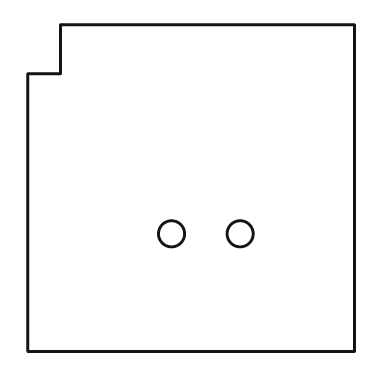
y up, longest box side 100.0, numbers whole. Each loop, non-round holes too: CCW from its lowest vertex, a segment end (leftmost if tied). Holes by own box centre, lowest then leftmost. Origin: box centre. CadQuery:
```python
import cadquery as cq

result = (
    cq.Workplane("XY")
    .moveTo(-50.0, -50.0)
    .lineTo(50.0, -50.0)
    .lineTo(50.0, 50.0)
    .lineTo(-40.0, 50.0)
    .lineTo(-40.0, 35.0)
    .lineTo(-50.0, 35.0)
    .close()
    .moveTo(-6.0, -14.0)
    .circle(4.0)
    .moveTo(15.0, -14.0)
    .circle(4.0)
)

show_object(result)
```